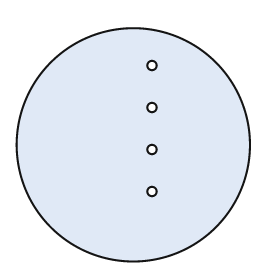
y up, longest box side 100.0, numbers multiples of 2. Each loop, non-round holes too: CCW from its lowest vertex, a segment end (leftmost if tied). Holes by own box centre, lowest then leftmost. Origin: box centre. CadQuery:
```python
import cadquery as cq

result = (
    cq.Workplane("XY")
    .moveTo(0.0, 0.0)
    .circle(50.0)
    .moveTo(8.0, -20.0)
    .circle(2.0)
    .moveTo(8.0, -2.0)
    .circle(2.0)
    .moveTo(8.0, 16.0)
    .circle(2.0)
    .moveTo(8.0, 34.0)
    .circle(2.0)
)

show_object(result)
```